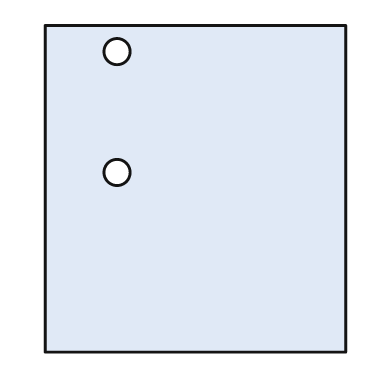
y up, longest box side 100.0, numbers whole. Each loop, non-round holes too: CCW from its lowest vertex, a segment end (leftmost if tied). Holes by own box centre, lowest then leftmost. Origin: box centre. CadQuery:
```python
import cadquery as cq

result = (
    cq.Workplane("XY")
    .moveTo(-46.0, -50.0)
    .lineTo(46.0, -50.0)
    .lineTo(46.0, 50.0)
    .lineTo(-46.0, 50.0)
    .close()
    .moveTo(-24.0, 5.0)
    .circle(4.0)
    .moveTo(-24.0, 42.0)
    .circle(4.0)
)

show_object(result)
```